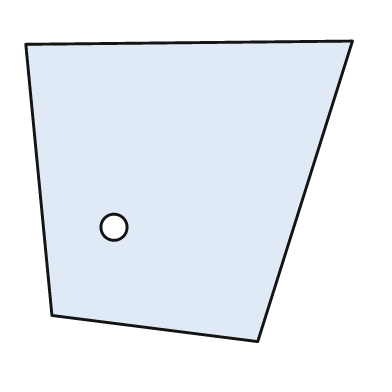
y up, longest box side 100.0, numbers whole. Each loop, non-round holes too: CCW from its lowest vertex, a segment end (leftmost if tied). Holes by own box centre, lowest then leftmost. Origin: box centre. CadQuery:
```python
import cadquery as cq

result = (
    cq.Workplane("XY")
    .moveTo(21.0, -46.0)
    .lineTo(50.0, 46.0)
    .lineTo(-50.0, 45.0)
    .lineTo(-42.0, -38.0)
    .close()
    .moveTo(-23.0, -11.0)
    .circle(4.0)
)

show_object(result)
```